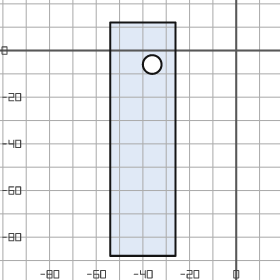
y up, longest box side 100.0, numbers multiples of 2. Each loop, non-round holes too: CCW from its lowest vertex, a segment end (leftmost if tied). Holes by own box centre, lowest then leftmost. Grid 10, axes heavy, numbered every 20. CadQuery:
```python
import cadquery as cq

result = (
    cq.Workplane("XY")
    .moveTo(-54.0, -88.0)
    .lineTo(-26.0, -88.0)
    .lineTo(-26.0, 12.0)
    .lineTo(-54.0, 12.0)
    .close()
    .moveTo(-36.0, -6.0)
    .circle(4.0)
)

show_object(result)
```